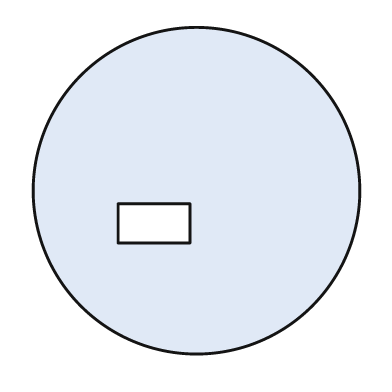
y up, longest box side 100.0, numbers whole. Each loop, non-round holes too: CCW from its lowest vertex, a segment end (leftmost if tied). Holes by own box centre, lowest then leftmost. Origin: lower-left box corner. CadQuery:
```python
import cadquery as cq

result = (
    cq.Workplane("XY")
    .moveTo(50.0, 50.0)
    .circle(50.0)
    .moveTo(26.0, 34.0)
    .lineTo(48.0, 34.0)
    .lineTo(48.0, 46.0)
    .lineTo(26.0, 46.0)
    .close()
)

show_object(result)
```